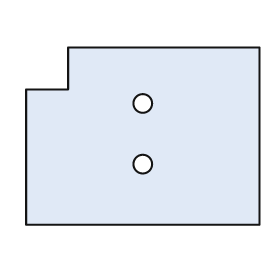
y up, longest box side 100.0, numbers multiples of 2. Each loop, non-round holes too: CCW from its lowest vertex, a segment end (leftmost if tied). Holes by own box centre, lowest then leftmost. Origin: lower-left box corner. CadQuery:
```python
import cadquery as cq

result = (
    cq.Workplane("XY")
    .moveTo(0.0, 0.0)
    .lineTo(100.0, 0.0)
    .lineTo(100.0, 76.0)
    .lineTo(18.0, 76.0)
    .lineTo(18.0, 58.0)
    .lineTo(0.0, 58.0)
    .close()
    .moveTo(50.0, 26.0)
    .circle(4.0)
    .moveTo(50.0, 52.0)
    .circle(4.0)
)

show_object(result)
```